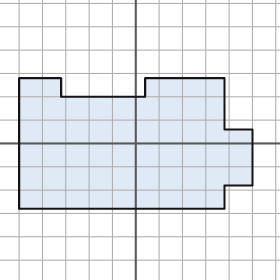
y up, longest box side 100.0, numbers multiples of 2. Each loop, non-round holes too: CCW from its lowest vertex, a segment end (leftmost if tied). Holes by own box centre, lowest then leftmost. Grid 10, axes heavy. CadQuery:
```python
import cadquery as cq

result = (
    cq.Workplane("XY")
    .moveTo(-50.0, -28.0)
    .lineTo(38.0, -28.0)
    .lineTo(38.0, -18.0)
    .lineTo(50.0, -18.0)
    .lineTo(50.0, 6.0)
    .lineTo(38.0, 6.0)
    .lineTo(38.0, 28.0)
    .lineTo(4.0, 28.0)
    .lineTo(4.0, 20.0)
    .lineTo(-32.0, 20.0)
    .lineTo(-32.0, 28.0)
    .lineTo(-50.0, 28.0)
    .close()
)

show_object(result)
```